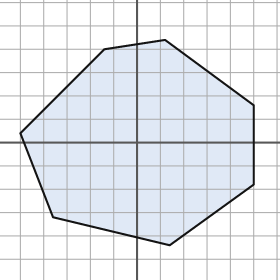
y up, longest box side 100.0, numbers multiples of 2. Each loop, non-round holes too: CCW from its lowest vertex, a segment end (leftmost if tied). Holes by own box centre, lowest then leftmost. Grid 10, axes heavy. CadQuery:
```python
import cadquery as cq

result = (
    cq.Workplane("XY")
    .moveTo(14.0, -44.0)
    .lineTo(50.0, -18.0)
    .lineTo(50.0, 16.0)
    .lineTo(12.0, 44.0)
    .lineTo(-14.0, 40.0)
    .lineTo(-50.0, 4.0)
    .lineTo(-36.0, -32.0)
    .close()
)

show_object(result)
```